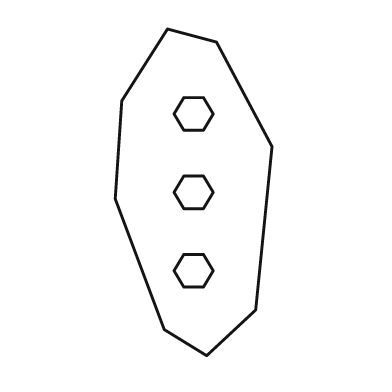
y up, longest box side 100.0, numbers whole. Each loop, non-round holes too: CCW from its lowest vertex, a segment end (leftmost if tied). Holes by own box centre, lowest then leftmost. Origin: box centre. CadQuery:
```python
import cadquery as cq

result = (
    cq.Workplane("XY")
    .moveTo(4.0, -50.0)
    .lineTo(19.0, -36.0)
    .lineTo(24.0, 14.0)
    .lineTo(7.0, 46.0)
    .lineTo(-8.0, 50.0)
    .lineTo(-22.0, 28.0)
    .lineTo(-24.0, -2.0)
    .lineTo(-9.0, -42.0)
    .close()
    .moveTo(-3.0, -29.0)
    .lineTo(3.0, -29.0)
    .lineTo(6.0, -24.0)
    .lineTo(3.0, -19.0)
    .lineTo(-3.0, -19.0)
    .lineTo(-6.0, -24.0)
    .close()
    .moveTo(-3.0, -5.0)
    .lineTo(3.0, -5.0)
    .lineTo(6.0, 0.0)
    .lineTo(3.0, 5.0)
    .lineTo(-3.0, 5.0)
    .lineTo(-6.0, 0.0)
    .close()
    .moveTo(-3.0, 19.0)
    .lineTo(3.0, 19.0)
    .lineTo(6.0, 24.0)
    .lineTo(3.0, 29.0)
    .lineTo(-3.0, 29.0)
    .lineTo(-6.0, 24.0)
    .close()
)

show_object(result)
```